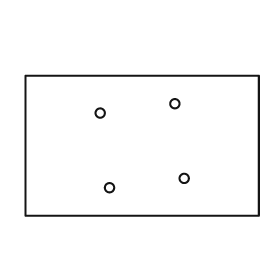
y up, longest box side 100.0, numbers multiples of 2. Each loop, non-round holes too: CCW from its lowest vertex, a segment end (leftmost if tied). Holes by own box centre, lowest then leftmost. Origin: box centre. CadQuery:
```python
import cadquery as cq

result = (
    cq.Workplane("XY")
    .moveTo(-50.0, -30.0)
    .lineTo(50.0, -30.0)
    .lineTo(50.0, 30.0)
    .lineTo(-50.0, 30.0)
    .close()
    .moveTo(-14.0, -18.0)
    .circle(2.0)
    .moveTo(18.0, -14.0)
    .circle(2.0)
    .moveTo(-18.0, 14.0)
    .circle(2.0)
    .moveTo(14.0, 18.0)
    .circle(2.0)
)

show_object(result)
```